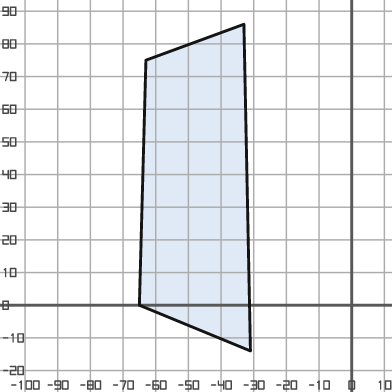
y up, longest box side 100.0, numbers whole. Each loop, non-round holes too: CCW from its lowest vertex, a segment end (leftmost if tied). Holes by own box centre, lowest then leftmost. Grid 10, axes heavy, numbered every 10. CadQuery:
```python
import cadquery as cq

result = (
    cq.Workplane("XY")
    .moveTo(-31.0, -14.0)
    .lineTo(-33.0, 86.0)
    .lineTo(-63.0, 75.0)
    .lineTo(-65.0, 0.0)
    .close()
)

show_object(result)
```